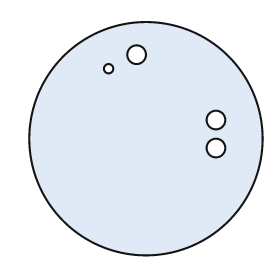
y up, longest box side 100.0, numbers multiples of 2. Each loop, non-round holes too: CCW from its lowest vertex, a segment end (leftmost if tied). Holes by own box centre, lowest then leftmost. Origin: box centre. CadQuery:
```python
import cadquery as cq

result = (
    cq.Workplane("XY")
    .moveTo(0.0, 0.0)
    .circle(50.0)
    .moveTo(30.0, -4.0)
    .circle(4.0)
    .moveTo(30.0, 8.0)
    .circle(4.0)
    .moveTo(-16.0, 30.0)
    .circle(2.0)
    .moveTo(-4.0, 36.0)
    .circle(4.0)
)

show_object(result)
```